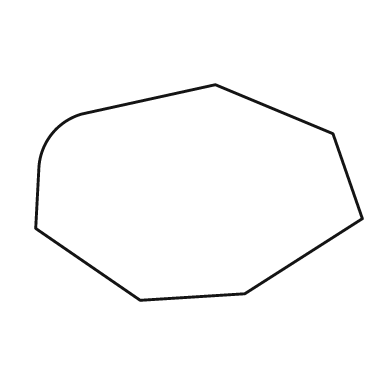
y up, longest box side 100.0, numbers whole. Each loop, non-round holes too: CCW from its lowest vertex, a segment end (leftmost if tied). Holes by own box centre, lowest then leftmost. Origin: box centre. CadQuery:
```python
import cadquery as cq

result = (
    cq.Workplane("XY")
    .moveTo(-18.0, -33.0)
    .lineTo(14.0, -31.0)
    .lineTo(50.0, -8.0)
    .lineTo(41.0, 18.0)
    .lineTo(5.0, 33.0)
    .lineTo(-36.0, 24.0)
    .threePointArc((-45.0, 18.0), (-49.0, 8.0))
    .lineTo(-50.0, -11.0)
    .close()
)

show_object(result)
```